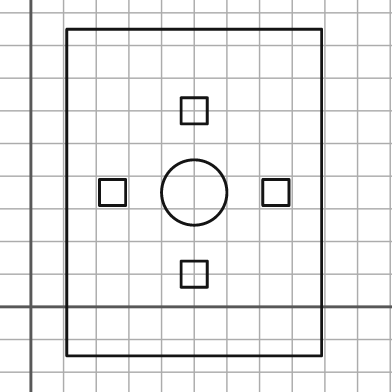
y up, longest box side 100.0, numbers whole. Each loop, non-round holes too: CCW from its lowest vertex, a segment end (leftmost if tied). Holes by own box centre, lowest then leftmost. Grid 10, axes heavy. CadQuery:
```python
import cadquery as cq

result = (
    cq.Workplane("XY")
    .moveTo(11.0, -15.0)
    .lineTo(89.0, -15.0)
    .lineTo(89.0, 85.0)
    .lineTo(11.0, 85.0)
    .close()
    .moveTo(46.0, 6.0)
    .lineTo(54.0, 6.0)
    .lineTo(54.0, 14.0)
    .lineTo(46.0, 14.0)
    .close()
    .moveTo(21.0, 31.0)
    .lineTo(29.0, 31.0)
    .lineTo(29.0, 39.0)
    .lineTo(21.0, 39.0)
    .close()
    .moveTo(50.0, 35.0)
    .circle(10.0)
    .moveTo(71.0, 31.0)
    .lineTo(79.0, 31.0)
    .lineTo(79.0, 39.0)
    .lineTo(71.0, 39.0)
    .close()
    .moveTo(46.0, 56.0)
    .lineTo(54.0, 56.0)
    .lineTo(54.0, 64.0)
    .lineTo(46.0, 64.0)
    .close()
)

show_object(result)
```